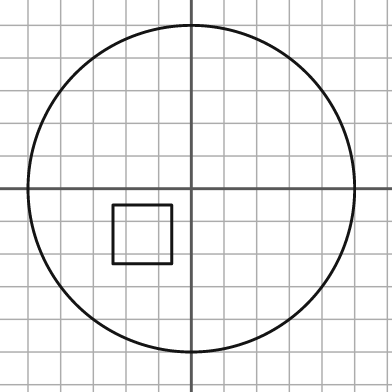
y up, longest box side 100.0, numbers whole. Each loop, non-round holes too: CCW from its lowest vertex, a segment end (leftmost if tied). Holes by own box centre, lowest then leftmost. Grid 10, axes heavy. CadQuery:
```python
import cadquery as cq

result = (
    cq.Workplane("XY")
    .moveTo(0.0, 0.0)
    .circle(50.0)
    .moveTo(-24.0, -23.0)
    .lineTo(-6.0, -23.0)
    .lineTo(-6.0, -5.0)
    .lineTo(-24.0, -5.0)
    .close()
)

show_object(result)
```